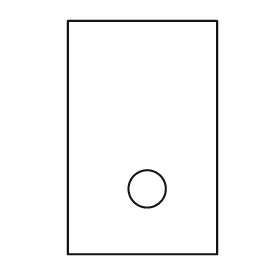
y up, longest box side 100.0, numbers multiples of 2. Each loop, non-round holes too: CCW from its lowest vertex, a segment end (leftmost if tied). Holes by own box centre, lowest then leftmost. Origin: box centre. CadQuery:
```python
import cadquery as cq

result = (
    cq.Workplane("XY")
    .moveTo(-32.0, -50.0)
    .lineTo(32.0, -50.0)
    .lineTo(32.0, 50.0)
    .lineTo(-32.0, 50.0)
    .close()
    .moveTo(2.0, -22.0)
    .circle(8.0)
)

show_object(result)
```